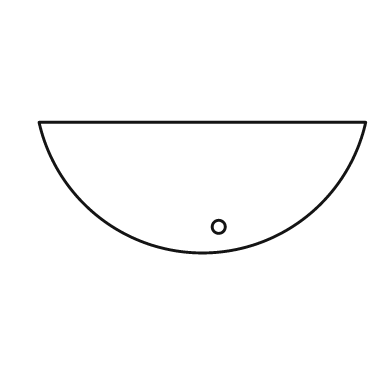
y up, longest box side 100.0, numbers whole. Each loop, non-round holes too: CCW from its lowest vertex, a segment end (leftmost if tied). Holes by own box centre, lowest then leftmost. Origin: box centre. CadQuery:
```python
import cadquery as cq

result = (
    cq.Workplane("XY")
    .moveTo(-50.0, 20.0)
    .threePointArc((0.0, -20.0), (50.0, 20.0))
    .close()
    .moveTo(5.0, -12.0)
    .circle(2.0)
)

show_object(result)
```